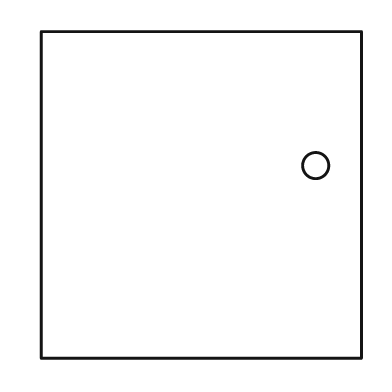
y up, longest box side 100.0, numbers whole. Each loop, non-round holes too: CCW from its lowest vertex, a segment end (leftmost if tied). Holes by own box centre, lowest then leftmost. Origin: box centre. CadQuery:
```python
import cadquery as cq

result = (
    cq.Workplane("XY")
    .moveTo(-49.0, -50.0)
    .lineTo(49.0, -50.0)
    .lineTo(49.0, 50.0)
    .lineTo(-49.0, 50.0)
    .close()
    .moveTo(35.0, 9.0)
    .circle(4.0)
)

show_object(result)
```